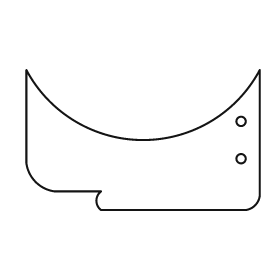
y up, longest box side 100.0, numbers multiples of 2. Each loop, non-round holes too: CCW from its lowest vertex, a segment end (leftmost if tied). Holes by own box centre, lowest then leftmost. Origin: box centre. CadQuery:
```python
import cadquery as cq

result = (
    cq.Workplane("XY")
    .moveTo(-18.0, -30.0)
    .lineTo(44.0, -30.0)
    .threePointArc((48.0, -28.0), (50.0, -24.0))
    .lineTo(50.0, 30.0)
    .threePointArc((0.0, 0.0), (-50.0, 30.0))
    .lineTo(-50.0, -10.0)
    .threePointArc((-46.0, -18.0), (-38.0, -22.0))
    .lineTo(-18.0, -22.0)
    .threePointArc((-20.0, -26.0), (-18.0, -30.0))
    .close()
    .moveTo(42.0, -8.0)
    .circle(2.0)
    .moveTo(42.0, 8.0)
    .circle(2.0)
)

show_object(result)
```